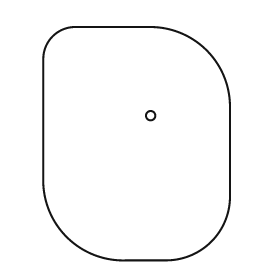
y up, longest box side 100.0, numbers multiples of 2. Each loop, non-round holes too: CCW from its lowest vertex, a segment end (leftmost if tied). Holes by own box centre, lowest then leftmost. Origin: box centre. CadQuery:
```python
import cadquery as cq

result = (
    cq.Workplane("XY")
    .moveTo(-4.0, -50.0)
    .lineTo(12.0, -50.0)
    .threePointArc((32.0, -42.0), (40.0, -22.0))
    .lineTo(40.0, 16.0)
    .threePointArc((30.0, 40.0), (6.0, 50.0))
    .lineTo(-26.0, 50.0)
    .threePointArc((-36.0, 46.0), (-40.0, 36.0))
    .lineTo(-40.0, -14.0)
    .threePointArc((-30.0, -40.0), (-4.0, -50.0))
    .close()
    .moveTo(6.0, 12.0)
    .circle(2.0)
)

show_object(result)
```